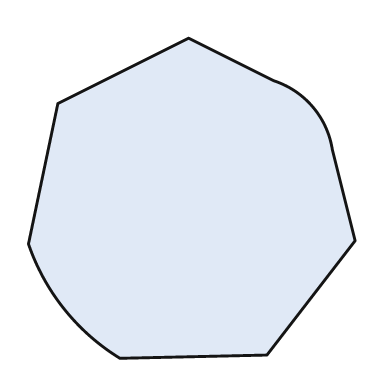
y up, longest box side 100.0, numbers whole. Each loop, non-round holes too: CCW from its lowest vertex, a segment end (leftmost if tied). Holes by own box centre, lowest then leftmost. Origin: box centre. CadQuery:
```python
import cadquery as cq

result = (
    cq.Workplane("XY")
    .moveTo(-22.0, -49.0)
    .lineTo(23.0, -48.0)
    .lineTo(50.0, -13.0)
    .lineTo(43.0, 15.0)
    .threePointArc((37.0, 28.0), (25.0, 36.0))
    .lineTo(-1.0, 49.0)
    .lineTo(-41.0, 29.0)
    .lineTo(-50.0, -14.0)
    .threePointArc((-39.0, -34.0), (-22.0, -49.0))
    .close()
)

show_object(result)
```